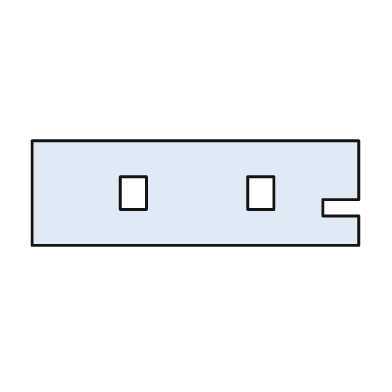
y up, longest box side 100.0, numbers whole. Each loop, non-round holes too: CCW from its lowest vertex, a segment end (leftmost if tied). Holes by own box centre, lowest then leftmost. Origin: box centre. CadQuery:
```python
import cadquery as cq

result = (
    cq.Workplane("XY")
    .moveTo(-50.0, -16.0)
    .lineTo(50.0, -16.0)
    .lineTo(50.0, -7.0)
    .lineTo(39.0, -7.0)
    .lineTo(39.0, -2.0)
    .lineTo(50.0, -2.0)
    .lineTo(50.0, 16.0)
    .lineTo(-50.0, 16.0)
    .close()
    .moveTo(-23.0, -5.0)
    .lineTo(-15.0, -5.0)
    .lineTo(-15.0, 5.0)
    .lineTo(-23.0, 5.0)
    .close()
    .moveTo(16.0, -5.0)
    .lineTo(24.0, -5.0)
    .lineTo(24.0, 5.0)
    .lineTo(16.0, 5.0)
    .close()
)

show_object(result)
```